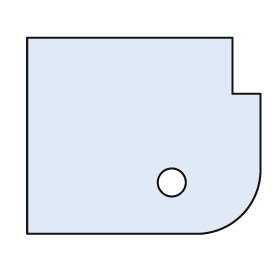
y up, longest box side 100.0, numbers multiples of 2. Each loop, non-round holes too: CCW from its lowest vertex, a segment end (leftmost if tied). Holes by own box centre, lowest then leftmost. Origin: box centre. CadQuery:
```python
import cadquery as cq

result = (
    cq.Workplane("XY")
    .moveTo(-50.0, -42.0)
    .lineTo(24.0, -42.0)
    .threePointArc((42.0, -34.0), (50.0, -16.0))
    .lineTo(50.0, 18.0)
    .lineTo(38.0, 18.0)
    .lineTo(38.0, 42.0)
    .lineTo(-50.0, 42.0)
    .close()
    .moveTo(12.0, -20.0)
    .circle(6.0)
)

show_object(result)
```